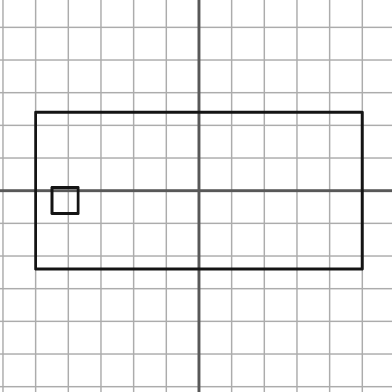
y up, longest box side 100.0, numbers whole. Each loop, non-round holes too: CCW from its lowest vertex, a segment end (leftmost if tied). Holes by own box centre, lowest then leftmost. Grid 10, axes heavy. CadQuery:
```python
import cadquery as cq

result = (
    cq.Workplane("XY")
    .moveTo(-50.0, -24.0)
    .lineTo(50.0, -24.0)
    .lineTo(50.0, 24.0)
    .lineTo(-50.0, 24.0)
    .close()
    .moveTo(-45.0, -7.0)
    .lineTo(-37.0, -7.0)
    .lineTo(-37.0, 1.0)
    .lineTo(-45.0, 1.0)
    .close()
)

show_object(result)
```